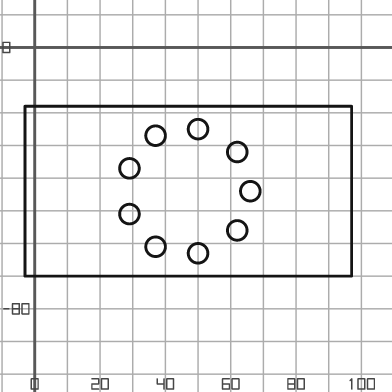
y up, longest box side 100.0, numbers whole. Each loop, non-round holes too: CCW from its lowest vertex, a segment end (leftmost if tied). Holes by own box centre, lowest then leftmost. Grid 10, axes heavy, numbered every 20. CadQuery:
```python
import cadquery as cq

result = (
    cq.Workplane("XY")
    .moveTo(-3.0, -70.0)
    .lineTo(97.0, -70.0)
    .lineTo(97.0, -18.0)
    .lineTo(-3.0, -18.0)
    .close()
    .moveTo(50.0, -63.0)
    .circle(3.0)
    .moveTo(37.0, -61.0)
    .circle(3.0)
    .moveTo(62.0, -56.0)
    .circle(3.0)
    .moveTo(29.0, -51.0)
    .circle(3.0)
    .moveTo(66.0, -44.0)
    .circle(3.0)
    .moveTo(29.0, -37.0)
    .circle(3.0)
    .moveTo(62.0, -32.0)
    .circle(3.0)
    .moveTo(37.0, -27.0)
    .circle(3.0)
    .moveTo(50.0, -25.0)
    .circle(3.0)
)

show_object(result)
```